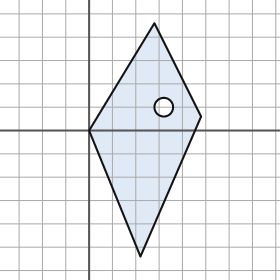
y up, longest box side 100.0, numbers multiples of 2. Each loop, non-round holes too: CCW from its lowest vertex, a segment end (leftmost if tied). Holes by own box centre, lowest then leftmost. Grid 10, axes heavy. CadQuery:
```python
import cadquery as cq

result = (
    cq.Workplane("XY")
    .moveTo(22.0, -54.0)
    .lineTo(48.0, 6.0)
    .lineTo(28.0, 46.0)
    .lineTo(0.0, 0.0)
    .close()
    .moveTo(32.0, 10.0)
    .circle(4.0)
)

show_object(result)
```